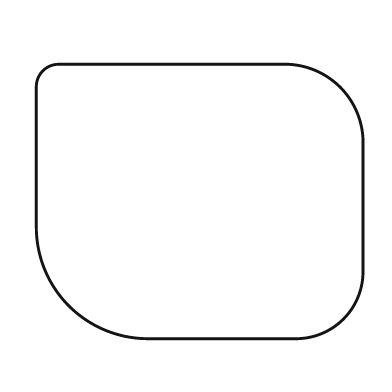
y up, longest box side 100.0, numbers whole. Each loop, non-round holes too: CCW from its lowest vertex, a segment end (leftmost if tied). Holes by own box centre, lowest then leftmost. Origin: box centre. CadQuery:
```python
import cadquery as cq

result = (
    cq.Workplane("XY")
    .moveTo(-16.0, -42.0)
    .lineTo(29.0, -42.0)
    .threePointArc((44.0, -36.0), (50.0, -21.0))
    .lineTo(50.0, 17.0)
    .threePointArc((43.0, 35.0), (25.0, 42.0))
    .lineTo(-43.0, 42.0)
    .threePointArc((-48.0, 40.0), (-50.0, 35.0))
    .lineTo(-50.0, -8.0)
    .threePointArc((-40.0, -32.0), (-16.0, -42.0))
    .close()
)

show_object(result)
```